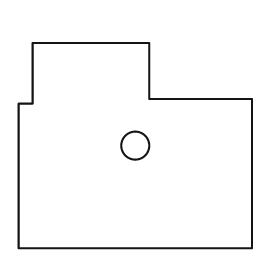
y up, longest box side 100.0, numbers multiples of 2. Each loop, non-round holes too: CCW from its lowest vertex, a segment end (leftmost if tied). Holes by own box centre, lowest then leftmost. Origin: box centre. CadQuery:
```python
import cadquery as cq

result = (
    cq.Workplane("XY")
    .moveTo(-50.0, -44.0)
    .lineTo(50.0, -44.0)
    .lineTo(50.0, 20.0)
    .lineTo(6.0, 20.0)
    .lineTo(6.0, 44.0)
    .lineTo(-44.0, 44.0)
    .lineTo(-44.0, 18.0)
    .lineTo(-50.0, 18.0)
    .close()
    .moveTo(0.0, 0.0)
    .circle(6.0)
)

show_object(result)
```